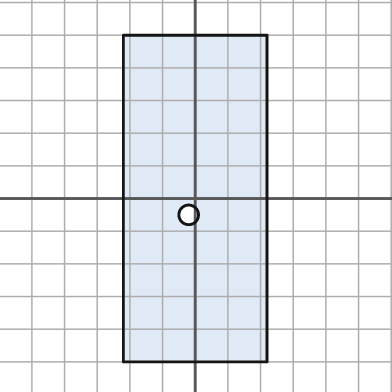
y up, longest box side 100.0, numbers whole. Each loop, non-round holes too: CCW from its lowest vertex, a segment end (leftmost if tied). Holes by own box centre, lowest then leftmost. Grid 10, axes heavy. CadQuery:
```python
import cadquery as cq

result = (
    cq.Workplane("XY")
    .moveTo(-22.0, -50.0)
    .lineTo(22.0, -50.0)
    .lineTo(22.0, 50.0)
    .lineTo(-22.0, 50.0)
    .close()
    .moveTo(-2.0, -5.0)
    .circle(3.0)
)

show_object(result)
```